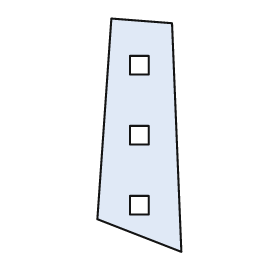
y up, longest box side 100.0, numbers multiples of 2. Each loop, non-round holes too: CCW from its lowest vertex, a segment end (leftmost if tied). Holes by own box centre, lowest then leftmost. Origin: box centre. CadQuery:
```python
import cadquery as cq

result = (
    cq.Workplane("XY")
    .moveTo(18.0, -50.0)
    .lineTo(14.0, 48.0)
    .lineTo(-12.0, 50.0)
    .lineTo(-18.0, -36.0)
    .close()
    .moveTo(-4.0, -34.0)
    .lineTo(4.0, -34.0)
    .lineTo(4.0, -26.0)
    .lineTo(-4.0, -26.0)
    .close()
    .moveTo(-4.0, -4.0)
    .lineTo(4.0, -4.0)
    .lineTo(4.0, 4.0)
    .lineTo(-4.0, 4.0)
    .close()
    .moveTo(-4.0, 26.0)
    .lineTo(4.0, 26.0)
    .lineTo(4.0, 34.0)
    .lineTo(-4.0, 34.0)
    .close()
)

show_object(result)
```